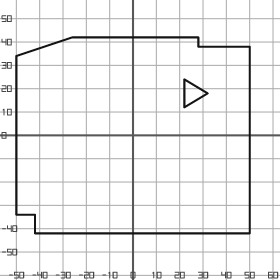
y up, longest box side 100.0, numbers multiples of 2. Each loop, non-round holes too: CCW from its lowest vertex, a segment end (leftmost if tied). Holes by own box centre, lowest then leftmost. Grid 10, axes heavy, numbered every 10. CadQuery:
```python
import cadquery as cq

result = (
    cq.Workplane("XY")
    .moveTo(-42.0, -42.0)
    .lineTo(50.0, -42.0)
    .lineTo(50.0, 38.0)
    .lineTo(28.0, 38.0)
    .lineTo(28.0, 42.0)
    .lineTo(-26.0, 42.0)
    .lineTo(-50.0, 34.0)
    .lineTo(-50.0, -34.0)
    .lineTo(-42.0, -34.0)
    .close()
    .moveTo(22.0, 12.0)
    .lineTo(32.0, 18.0)
    .lineTo(22.0, 24.0)
    .close()
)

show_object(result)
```